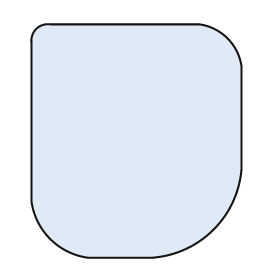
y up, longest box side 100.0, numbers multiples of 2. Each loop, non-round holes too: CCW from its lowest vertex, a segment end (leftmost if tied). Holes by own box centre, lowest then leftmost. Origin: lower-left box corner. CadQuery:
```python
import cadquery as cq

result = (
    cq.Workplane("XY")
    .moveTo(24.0, 0.0)
    .lineTo(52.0, 0.0)
    .threePointArc((78.0, 12.0), (90.0, 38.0))
    .lineTo(90.0, 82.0)
    .threePointArc((84.0, 94.0), (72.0, 100.0))
    .lineTo(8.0, 100.0)
    .threePointArc((2.0, 98.0), (0.0, 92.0))
    .lineTo(0.0, 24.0)
    .threePointArc((8.0, 8.0), (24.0, 0.0))
    .close()
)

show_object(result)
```